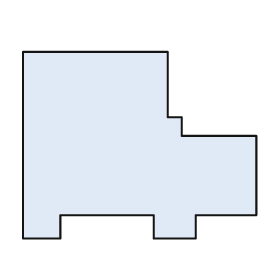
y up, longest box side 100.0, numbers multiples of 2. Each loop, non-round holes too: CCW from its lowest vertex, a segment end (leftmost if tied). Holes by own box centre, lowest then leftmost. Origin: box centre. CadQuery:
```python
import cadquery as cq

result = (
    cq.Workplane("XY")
    .moveTo(-50.0, -40.0)
    .lineTo(-34.0, -40.0)
    .lineTo(-34.0, -30.0)
    .lineTo(6.0, -30.0)
    .lineTo(6.0, -40.0)
    .lineTo(24.0, -40.0)
    .lineTo(24.0, -30.0)
    .lineTo(50.0, -30.0)
    .lineTo(50.0, 4.0)
    .lineTo(18.0, 4.0)
    .lineTo(18.0, 12.0)
    .lineTo(12.0, 12.0)
    .lineTo(12.0, 40.0)
    .lineTo(-50.0, 40.0)
    .close()
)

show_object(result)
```